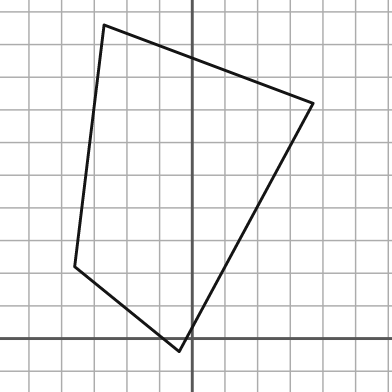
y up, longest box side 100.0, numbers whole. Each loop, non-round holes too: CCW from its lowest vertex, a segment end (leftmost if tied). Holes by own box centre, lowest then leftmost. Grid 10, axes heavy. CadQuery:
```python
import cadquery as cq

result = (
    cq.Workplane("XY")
    .moveTo(-4.0, -4.0)
    .lineTo(37.0, 72.0)
    .lineTo(-27.0, 96.0)
    .lineTo(-36.0, 22.0)
    .close()
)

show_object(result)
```